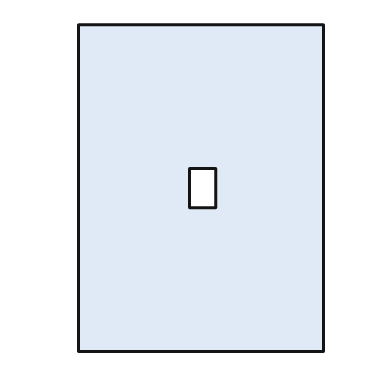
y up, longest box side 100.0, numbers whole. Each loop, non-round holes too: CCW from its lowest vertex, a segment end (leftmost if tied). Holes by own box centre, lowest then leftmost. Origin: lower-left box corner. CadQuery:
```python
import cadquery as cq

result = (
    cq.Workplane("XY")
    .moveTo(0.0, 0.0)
    .lineTo(75.0, 0.0)
    .lineTo(75.0, 100.0)
    .lineTo(0.0, 100.0)
    .close()
    .moveTo(34.0, 44.0)
    .lineTo(42.0, 44.0)
    .lineTo(42.0, 56.0)
    .lineTo(34.0, 56.0)
    .close()
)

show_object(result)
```